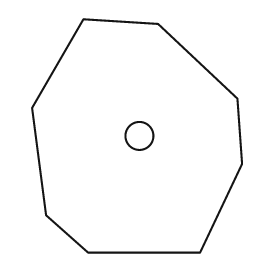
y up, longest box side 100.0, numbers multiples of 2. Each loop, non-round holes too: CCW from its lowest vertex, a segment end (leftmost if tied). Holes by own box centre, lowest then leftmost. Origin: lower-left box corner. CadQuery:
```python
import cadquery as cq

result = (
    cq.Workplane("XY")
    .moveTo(24.0, 0.0)
    .lineTo(72.0, 0.0)
    .lineTo(90.0, 38.0)
    .lineTo(88.0, 66.0)
    .lineTo(54.0, 98.0)
    .lineTo(22.0, 100.0)
    .lineTo(0.0, 62.0)
    .lineTo(6.0, 16.0)
    .close()
    .moveTo(46.0, 50.0)
    .circle(6.0)
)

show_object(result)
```